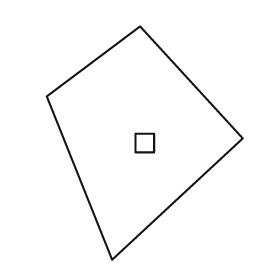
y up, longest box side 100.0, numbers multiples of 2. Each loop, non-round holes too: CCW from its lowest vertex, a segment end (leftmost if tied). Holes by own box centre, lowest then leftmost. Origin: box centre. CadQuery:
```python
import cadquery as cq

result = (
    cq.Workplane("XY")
    .moveTo(-14.0, -50.0)
    .lineTo(42.0, 2.0)
    .lineTo(-2.0, 50.0)
    .lineTo(-42.0, 20.0)
    .close()
    .moveTo(-4.0, -4.0)
    .lineTo(4.0, -4.0)
    .lineTo(4.0, 4.0)
    .lineTo(-4.0, 4.0)
    .close()
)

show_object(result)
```